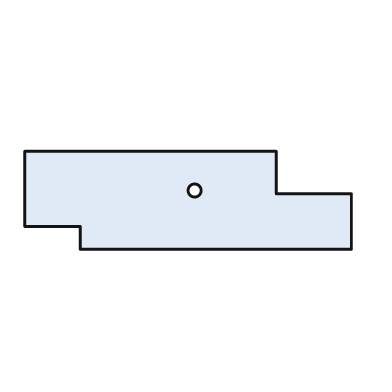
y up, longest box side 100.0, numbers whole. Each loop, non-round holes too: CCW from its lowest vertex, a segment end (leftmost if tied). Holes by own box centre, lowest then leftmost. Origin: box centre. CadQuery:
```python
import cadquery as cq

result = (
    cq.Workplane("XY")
    .moveTo(-33.0, -15.0)
    .lineTo(50.0, -15.0)
    .lineTo(50.0, 2.0)
    .lineTo(27.0, 2.0)
    .lineTo(27.0, 15.0)
    .lineTo(-50.0, 15.0)
    .lineTo(-50.0, -8.0)
    .lineTo(-33.0, -8.0)
    .close()
    .moveTo(2.0, 3.0)
    .circle(2.0)
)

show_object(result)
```